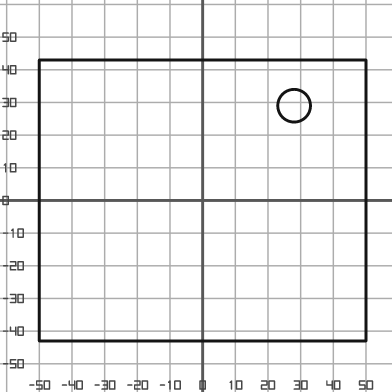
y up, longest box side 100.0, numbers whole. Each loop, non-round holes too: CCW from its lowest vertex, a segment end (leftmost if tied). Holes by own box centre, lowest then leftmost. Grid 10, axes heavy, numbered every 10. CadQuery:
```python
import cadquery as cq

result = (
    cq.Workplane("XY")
    .moveTo(-50.0, -43.0)
    .lineTo(50.0, -43.0)
    .lineTo(50.0, 43.0)
    .lineTo(-50.0, 43.0)
    .close()
    .moveTo(28.0, 29.0)
    .circle(5.0)
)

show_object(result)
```